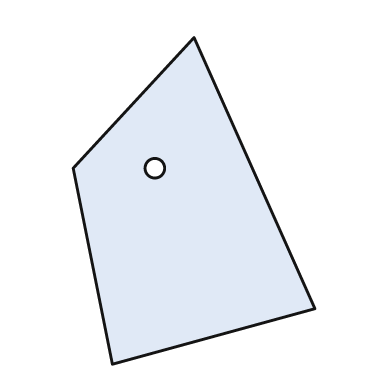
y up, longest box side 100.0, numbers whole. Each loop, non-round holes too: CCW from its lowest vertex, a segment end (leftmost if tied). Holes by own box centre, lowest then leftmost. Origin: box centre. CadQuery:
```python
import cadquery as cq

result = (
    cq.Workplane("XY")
    .moveTo(-25.0, -50.0)
    .lineTo(37.0, -33.0)
    .lineTo(0.0, 50.0)
    .lineTo(-37.0, 10.0)
    .close()
    .moveTo(-12.0, 10.0)
    .circle(3.0)
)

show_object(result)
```